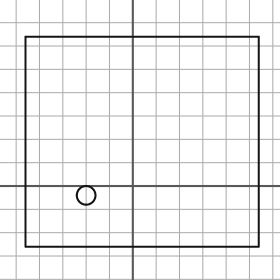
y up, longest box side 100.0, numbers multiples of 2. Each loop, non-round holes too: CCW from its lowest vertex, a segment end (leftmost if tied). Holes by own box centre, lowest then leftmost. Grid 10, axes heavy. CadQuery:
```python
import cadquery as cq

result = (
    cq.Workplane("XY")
    .moveTo(-46.0, -26.0)
    .lineTo(54.0, -26.0)
    .lineTo(54.0, 64.0)
    .lineTo(-46.0, 64.0)
    .close()
    .moveTo(-20.0, -4.0)
    .circle(4.0)
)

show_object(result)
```